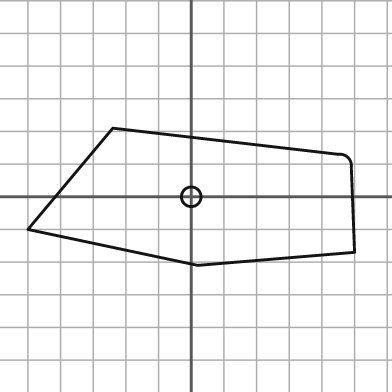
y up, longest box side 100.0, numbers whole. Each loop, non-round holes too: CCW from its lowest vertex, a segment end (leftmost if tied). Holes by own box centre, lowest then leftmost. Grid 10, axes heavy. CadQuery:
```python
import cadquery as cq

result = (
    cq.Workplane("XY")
    .moveTo(2.0, -21.0)
    .lineTo(50.0, -17.0)
    .lineTo(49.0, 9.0)
    .threePointArc((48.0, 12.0), (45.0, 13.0))
    .lineTo(-24.0, 21.0)
    .lineTo(-50.0, -10.0)
    .close()
    .moveTo(0.0, 0.0)
    .circle(3.0)
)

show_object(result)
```